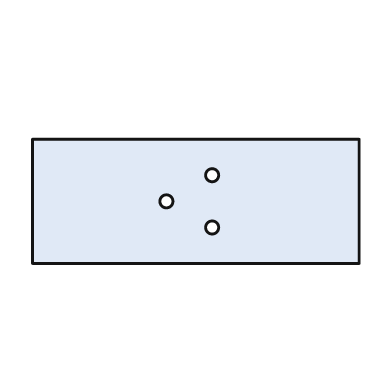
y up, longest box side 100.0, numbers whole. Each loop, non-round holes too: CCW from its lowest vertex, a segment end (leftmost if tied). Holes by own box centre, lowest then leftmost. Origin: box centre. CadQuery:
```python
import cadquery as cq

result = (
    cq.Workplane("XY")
    .moveTo(-50.0, -19.0)
    .lineTo(50.0, -19.0)
    .lineTo(50.0, 19.0)
    .lineTo(-50.0, 19.0)
    .close()
    .moveTo(5.0, -8.0)
    .circle(2.0)
    .moveTo(-9.0, 0.0)
    .circle(2.0)
    .moveTo(5.0, 8.0)
    .circle(2.0)
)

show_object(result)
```